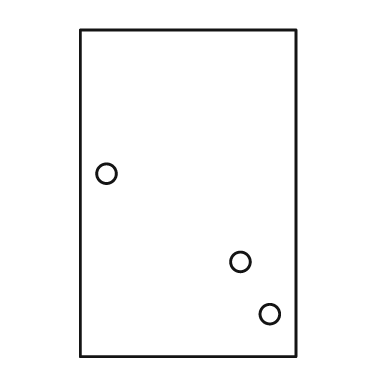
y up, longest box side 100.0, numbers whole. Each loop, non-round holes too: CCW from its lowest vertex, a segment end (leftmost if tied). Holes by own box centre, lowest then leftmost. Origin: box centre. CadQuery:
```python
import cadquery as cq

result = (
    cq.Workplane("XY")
    .moveTo(-33.0, -50.0)
    .lineTo(33.0, -50.0)
    .lineTo(33.0, 50.0)
    .lineTo(-33.0, 50.0)
    .close()
    .moveTo(25.0, -37.0)
    .circle(3.0)
    .moveTo(16.0, -21.0)
    .circle(3.0)
    .moveTo(-25.0, 6.0)
    .circle(3.0)
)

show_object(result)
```